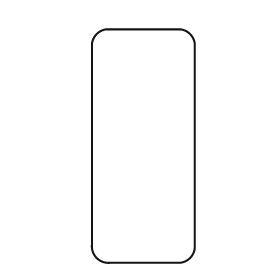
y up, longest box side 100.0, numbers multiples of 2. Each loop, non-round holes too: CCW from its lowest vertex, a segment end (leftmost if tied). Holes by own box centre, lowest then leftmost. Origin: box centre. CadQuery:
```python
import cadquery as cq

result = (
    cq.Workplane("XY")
    .moveTo(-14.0, -50.0)
    .lineTo(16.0, -50.0)
    .threePointArc((20.0, -48.0), (22.0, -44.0))
    .lineTo(22.0, 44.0)
    .threePointArc((20.0, 48.0), (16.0, 50.0))
    .lineTo(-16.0, 50.0)
    .threePointArc((-20.0, 48.0), (-22.0, 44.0))
    .lineTo(-22.0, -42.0)
    .threePointArc((-20.0, -48.0), (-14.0, -50.0))
    .close()
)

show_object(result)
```